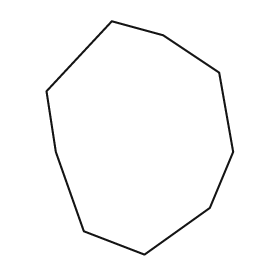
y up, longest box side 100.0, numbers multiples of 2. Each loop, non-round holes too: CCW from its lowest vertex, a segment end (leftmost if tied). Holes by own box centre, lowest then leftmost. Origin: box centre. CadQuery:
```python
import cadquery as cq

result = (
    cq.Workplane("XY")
    .moveTo(2.0, -50.0)
    .lineTo(30.0, -30.0)
    .lineTo(40.0, -6.0)
    .lineTo(34.0, 28.0)
    .lineTo(10.0, 44.0)
    .lineTo(-12.0, 50.0)
    .lineTo(-40.0, 20.0)
    .lineTo(-36.0, -6.0)
    .lineTo(-24.0, -40.0)
    .close()
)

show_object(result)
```